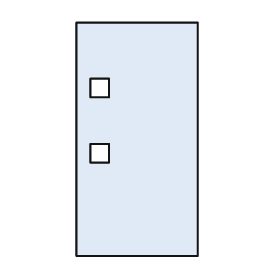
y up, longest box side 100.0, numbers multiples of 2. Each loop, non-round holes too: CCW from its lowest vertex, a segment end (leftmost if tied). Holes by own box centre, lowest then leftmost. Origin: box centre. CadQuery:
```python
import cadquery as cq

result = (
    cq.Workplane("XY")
    .moveTo(-26.0, -50.0)
    .lineTo(26.0, -50.0)
    .lineTo(26.0, 50.0)
    .lineTo(-26.0, 50.0)
    .close()
    .moveTo(-20.0, -10.0)
    .lineTo(-12.0, -10.0)
    .lineTo(-12.0, -2.0)
    .lineTo(-20.0, -2.0)
    .close()
    .moveTo(-20.0, 18.0)
    .lineTo(-12.0, 18.0)
    .lineTo(-12.0, 26.0)
    .lineTo(-20.0, 26.0)
    .close()
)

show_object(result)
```